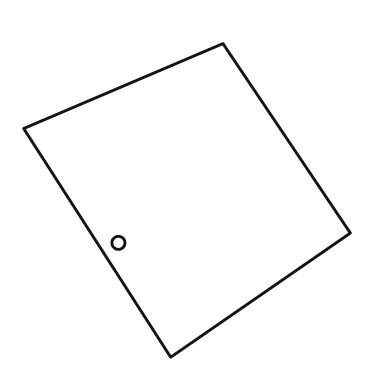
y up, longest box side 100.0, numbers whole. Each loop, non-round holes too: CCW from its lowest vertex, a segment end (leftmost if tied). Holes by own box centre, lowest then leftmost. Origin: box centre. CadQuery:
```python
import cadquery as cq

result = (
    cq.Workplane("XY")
    .moveTo(-5.0, -48.0)
    .lineTo(50.0, -10.0)
    .lineTo(11.0, 48.0)
    .lineTo(-50.0, 22.0)
    .close()
    .moveTo(-21.0, -13.0)
    .circle(2.0)
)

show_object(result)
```